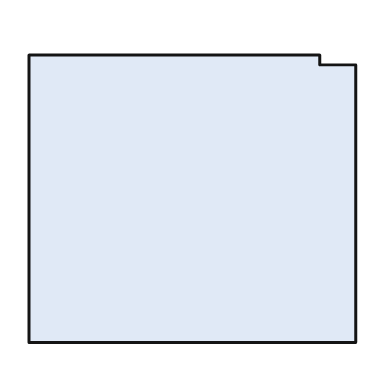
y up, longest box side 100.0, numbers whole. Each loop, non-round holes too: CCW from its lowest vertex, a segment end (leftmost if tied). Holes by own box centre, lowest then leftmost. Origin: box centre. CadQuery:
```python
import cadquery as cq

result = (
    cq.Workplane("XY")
    .moveTo(-50.0, -44.0)
    .lineTo(50.0, -44.0)
    .lineTo(50.0, 41.0)
    .lineTo(39.0, 41.0)
    .lineTo(39.0, 44.0)
    .lineTo(-50.0, 44.0)
    .close()
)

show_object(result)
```